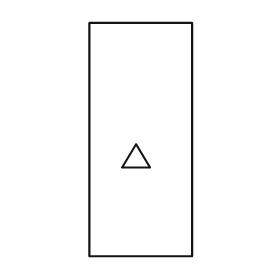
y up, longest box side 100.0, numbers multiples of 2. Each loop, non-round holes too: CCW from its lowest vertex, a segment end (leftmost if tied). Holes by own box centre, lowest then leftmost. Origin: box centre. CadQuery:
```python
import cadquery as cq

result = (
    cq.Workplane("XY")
    .moveTo(-22.0, -50.0)
    .lineTo(22.0, -50.0)
    .lineTo(22.0, 50.0)
    .lineTo(-22.0, 50.0)
    .close()
    .moveTo(-8.0, -12.0)
    .lineTo(4.0, -12.0)
    .lineTo(-2.0, -2.0)
    .close()
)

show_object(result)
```